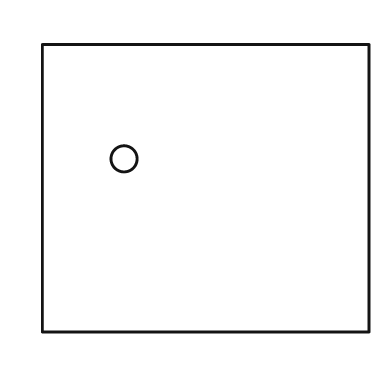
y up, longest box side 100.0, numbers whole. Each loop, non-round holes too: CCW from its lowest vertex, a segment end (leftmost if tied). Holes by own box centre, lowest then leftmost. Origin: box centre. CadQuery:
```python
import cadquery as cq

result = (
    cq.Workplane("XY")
    .moveTo(-50.0, -44.0)
    .lineTo(50.0, -44.0)
    .lineTo(50.0, 44.0)
    .lineTo(-50.0, 44.0)
    .close()
    .moveTo(-25.0, 9.0)
    .circle(4.0)
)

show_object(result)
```